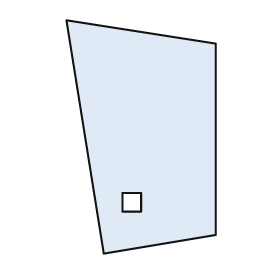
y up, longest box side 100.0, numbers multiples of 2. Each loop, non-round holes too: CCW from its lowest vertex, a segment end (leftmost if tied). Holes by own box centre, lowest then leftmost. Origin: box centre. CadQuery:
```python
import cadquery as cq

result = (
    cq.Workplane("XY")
    .moveTo(-16.0, -50.0)
    .lineTo(32.0, -42.0)
    .lineTo(32.0, 40.0)
    .lineTo(-32.0, 50.0)
    .close()
    .moveTo(-8.0, -32.0)
    .lineTo(0.0, -32.0)
    .lineTo(0.0, -24.0)
    .lineTo(-8.0, -24.0)
    .close()
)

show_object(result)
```